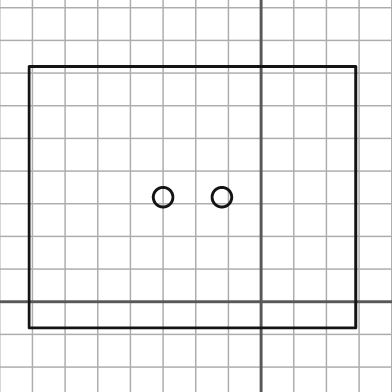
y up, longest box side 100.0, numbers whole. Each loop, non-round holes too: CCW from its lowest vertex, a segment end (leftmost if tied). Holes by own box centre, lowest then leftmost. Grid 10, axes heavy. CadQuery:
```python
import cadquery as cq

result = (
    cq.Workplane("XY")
    .moveTo(-71.0, -8.0)
    .lineTo(29.0, -8.0)
    .lineTo(29.0, 72.0)
    .lineTo(-71.0, 72.0)
    .close()
    .moveTo(-30.0, 32.0)
    .circle(3.0)
    .moveTo(-12.0, 32.0)
    .circle(3.0)
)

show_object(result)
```